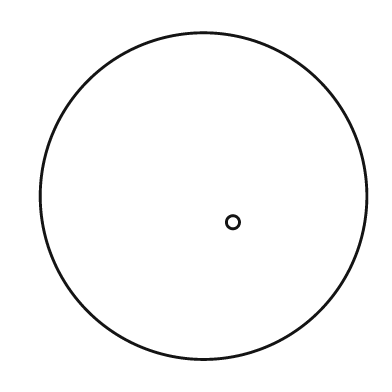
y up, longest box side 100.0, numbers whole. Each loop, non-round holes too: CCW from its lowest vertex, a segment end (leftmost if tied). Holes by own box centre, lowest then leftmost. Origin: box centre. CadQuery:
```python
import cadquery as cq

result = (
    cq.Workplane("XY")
    .moveTo(0.0, 0.0)
    .circle(50.0)
    .moveTo(9.0, -8.0)
    .circle(2.0)
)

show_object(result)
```